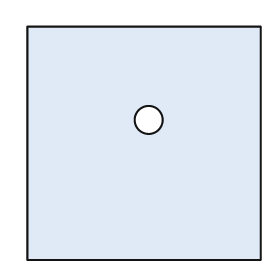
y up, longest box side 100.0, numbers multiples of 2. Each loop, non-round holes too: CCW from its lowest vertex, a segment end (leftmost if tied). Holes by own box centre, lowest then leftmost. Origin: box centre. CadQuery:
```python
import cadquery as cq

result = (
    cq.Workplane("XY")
    .moveTo(-50.0, -50.0)
    .lineTo(50.0, -50.0)
    .lineTo(50.0, 50.0)
    .lineTo(-50.0, 50.0)
    .close()
    .moveTo(2.0, 10.0)
    .circle(6.0)
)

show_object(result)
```